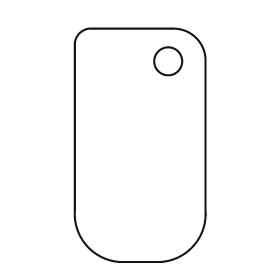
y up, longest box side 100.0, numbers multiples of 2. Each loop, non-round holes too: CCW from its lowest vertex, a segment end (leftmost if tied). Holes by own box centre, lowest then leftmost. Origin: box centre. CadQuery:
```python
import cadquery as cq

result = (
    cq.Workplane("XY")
    .moveTo(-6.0, -50.0)
    .lineTo(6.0, -50.0)
    .threePointArc((22.0, -44.0), (28.0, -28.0))
    .lineTo(28.0, 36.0)
    .threePointArc((24.0, 46.0), (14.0, 50.0))
    .lineTo(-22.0, 50.0)
    .threePointArc((-26.0, 48.0), (-28.0, 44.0))
    .lineTo(-28.0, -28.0)
    .threePointArc((-22.0, -44.0), (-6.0, -50.0))
    .close()
    .moveTo(12.0, 36.0)
    .circle(6.0)
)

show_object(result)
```